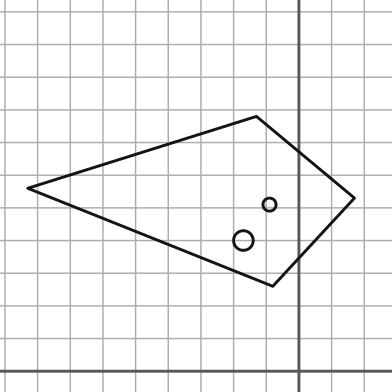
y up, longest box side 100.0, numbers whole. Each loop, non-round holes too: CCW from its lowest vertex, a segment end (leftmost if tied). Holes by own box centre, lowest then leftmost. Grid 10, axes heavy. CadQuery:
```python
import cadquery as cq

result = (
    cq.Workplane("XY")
    .moveTo(-8.0, 26.0)
    .lineTo(17.0, 53.0)
    .lineTo(-13.0, 78.0)
    .lineTo(-83.0, 56.0)
    .close()
    .moveTo(-17.0, 40.0)
    .circle(3.0)
    .moveTo(-9.0, 51.0)
    .circle(2.0)
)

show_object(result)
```